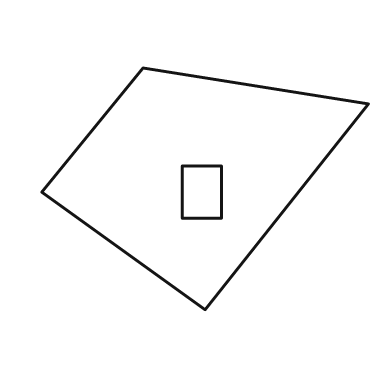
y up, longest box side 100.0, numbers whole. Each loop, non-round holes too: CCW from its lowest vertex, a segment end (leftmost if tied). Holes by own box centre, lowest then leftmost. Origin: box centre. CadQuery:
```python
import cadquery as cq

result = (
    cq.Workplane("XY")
    .moveTo(0.0, -37.0)
    .lineTo(50.0, 26.0)
    .lineTo(-19.0, 37.0)
    .lineTo(-50.0, -1.0)
    .close()
    .moveTo(-7.0, -9.0)
    .lineTo(5.0, -9.0)
    .lineTo(5.0, 7.0)
    .lineTo(-7.0, 7.0)
    .close()
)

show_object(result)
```